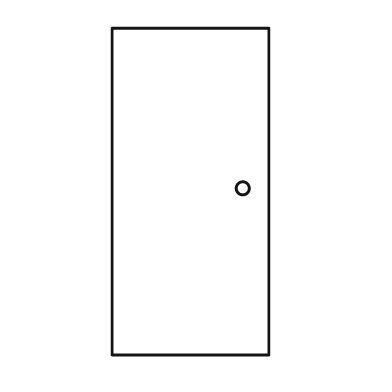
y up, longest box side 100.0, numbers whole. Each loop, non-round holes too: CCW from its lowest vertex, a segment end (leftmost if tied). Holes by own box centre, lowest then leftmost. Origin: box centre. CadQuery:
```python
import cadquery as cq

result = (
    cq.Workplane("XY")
    .moveTo(-24.0, -50.0)
    .lineTo(24.0, -50.0)
    .lineTo(24.0, 50.0)
    .lineTo(-24.0, 50.0)
    .close()
    .moveTo(16.0, 1.0)
    .circle(2.0)
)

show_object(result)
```